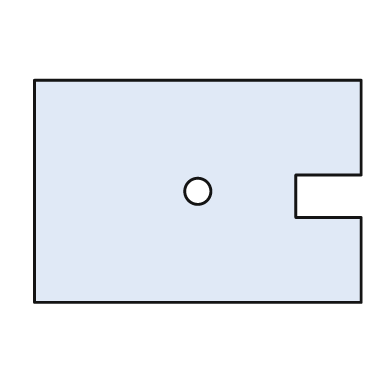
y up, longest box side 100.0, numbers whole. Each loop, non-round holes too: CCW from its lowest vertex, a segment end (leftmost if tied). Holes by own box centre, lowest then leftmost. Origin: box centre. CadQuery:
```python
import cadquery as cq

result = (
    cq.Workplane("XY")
    .moveTo(-50.0, -34.0)
    .lineTo(50.0, -34.0)
    .lineTo(50.0, -8.0)
    .lineTo(30.0, -8.0)
    .lineTo(30.0, 5.0)
    .lineTo(50.0, 5.0)
    .lineTo(50.0, 34.0)
    .lineTo(-50.0, 34.0)
    .close()
    .moveTo(0.0, 0.0)
    .circle(4.0)
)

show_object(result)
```